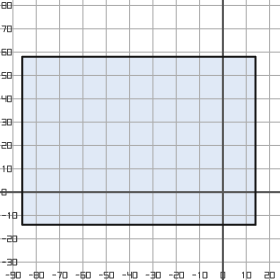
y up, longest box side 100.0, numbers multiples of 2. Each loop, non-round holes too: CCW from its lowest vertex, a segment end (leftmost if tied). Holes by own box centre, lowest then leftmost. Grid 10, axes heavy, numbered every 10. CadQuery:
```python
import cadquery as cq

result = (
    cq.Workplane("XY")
    .moveTo(-86.0, -14.0)
    .lineTo(14.0, -14.0)
    .lineTo(14.0, 58.0)
    .lineTo(-86.0, 58.0)
    .close()
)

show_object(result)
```